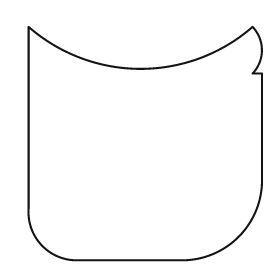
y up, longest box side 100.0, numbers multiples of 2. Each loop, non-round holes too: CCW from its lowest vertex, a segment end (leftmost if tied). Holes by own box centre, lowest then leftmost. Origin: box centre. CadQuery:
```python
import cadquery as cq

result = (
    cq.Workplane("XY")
    .moveTo(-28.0, -50.0)
    .lineTo(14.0, -50.0)
    .threePointArc((40.0, -40.0), (50.0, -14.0))
    .lineTo(50.0, 30.0)
    .lineTo(46.0, 30.0)
    .threePointArc((50.0, 40.0), (46.0, 50.0))
    .threePointArc((-2.0, 32.0), (-50.0, 50.0))
    .lineTo(-50.0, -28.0)
    .threePointArc((-44.0, -44.0), (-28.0, -50.0))
    .close()
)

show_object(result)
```